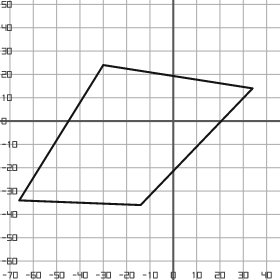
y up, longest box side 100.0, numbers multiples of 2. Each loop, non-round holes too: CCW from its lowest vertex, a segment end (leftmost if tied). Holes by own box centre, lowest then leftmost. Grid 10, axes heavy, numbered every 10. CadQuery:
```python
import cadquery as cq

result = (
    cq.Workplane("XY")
    .moveTo(-14.0, -36.0)
    .lineTo(34.0, 14.0)
    .lineTo(-30.0, 24.0)
    .lineTo(-66.0, -34.0)
    .close()
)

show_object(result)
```